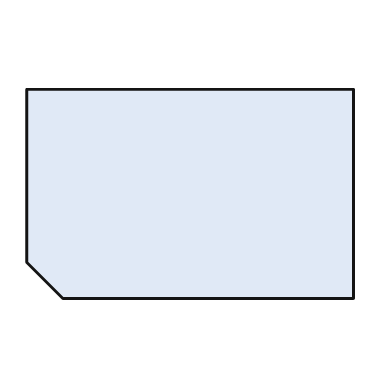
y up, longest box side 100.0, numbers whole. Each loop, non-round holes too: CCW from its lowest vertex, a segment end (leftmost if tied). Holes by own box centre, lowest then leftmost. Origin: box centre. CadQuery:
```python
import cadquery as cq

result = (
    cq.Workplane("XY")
    .moveTo(-39.0, -32.0)
    .lineTo(50.0, -32.0)
    .lineTo(50.0, 32.0)
    .lineTo(-50.0, 32.0)
    .lineTo(-50.0, -21.0)
    .close()
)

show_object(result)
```